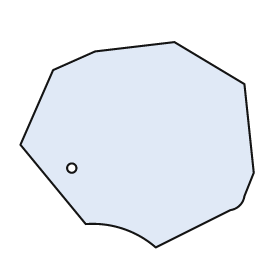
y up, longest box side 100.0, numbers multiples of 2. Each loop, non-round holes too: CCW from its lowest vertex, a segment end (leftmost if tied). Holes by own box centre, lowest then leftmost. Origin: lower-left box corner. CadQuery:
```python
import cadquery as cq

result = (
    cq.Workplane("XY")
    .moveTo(58.0, 0.0)
    .lineTo(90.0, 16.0)
    .threePointArc((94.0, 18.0), (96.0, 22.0))
    .lineTo(100.0, 32.0)
    .lineTo(96.0, 70.0)
    .lineTo(66.0, 88.0)
    .lineTo(32.0, 84.0)
    .lineTo(14.0, 76.0)
    .lineTo(0.0, 44.0)
    .lineTo(28.0, 10.0)
    .threePointArc((44.0, 8.0), (58.0, 0.0))
    .close()
    .moveTo(22.0, 34.0)
    .circle(2.0)
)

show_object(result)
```